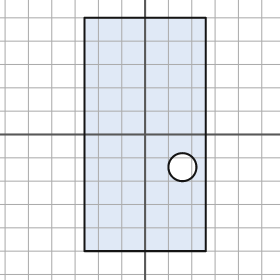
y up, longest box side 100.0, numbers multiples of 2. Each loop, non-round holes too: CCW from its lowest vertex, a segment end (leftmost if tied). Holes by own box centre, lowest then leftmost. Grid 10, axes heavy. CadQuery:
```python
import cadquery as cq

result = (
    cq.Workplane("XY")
    .moveTo(-26.0, -50.0)
    .lineTo(26.0, -50.0)
    .lineTo(26.0, 50.0)
    .lineTo(-26.0, 50.0)
    .close()
    .moveTo(16.0, -14.0)
    .circle(6.0)
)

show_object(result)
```